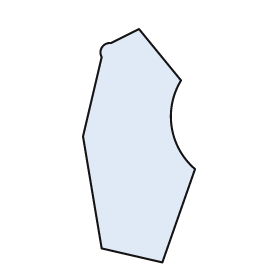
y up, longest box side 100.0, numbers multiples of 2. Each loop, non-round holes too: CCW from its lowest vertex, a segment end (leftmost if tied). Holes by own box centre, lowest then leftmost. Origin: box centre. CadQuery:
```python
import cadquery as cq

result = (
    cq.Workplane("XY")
    .moveTo(10.0, -50.0)
    .lineTo(24.0, -10.0)
    .threePointArc((14.0, 8.0), (18.0, 28.0))
    .lineTo(0.0, 50.0)
    .lineTo(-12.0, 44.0)
    .threePointArc((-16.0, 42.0), (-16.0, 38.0))
    .lineTo(-24.0, 4.0)
    .lineTo(-16.0, -44.0)
    .close()
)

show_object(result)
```